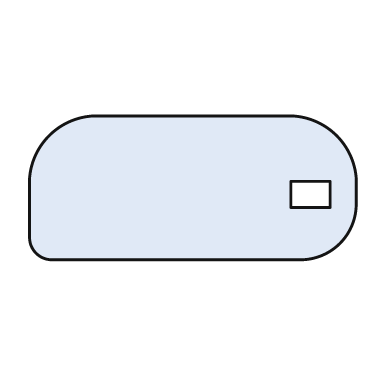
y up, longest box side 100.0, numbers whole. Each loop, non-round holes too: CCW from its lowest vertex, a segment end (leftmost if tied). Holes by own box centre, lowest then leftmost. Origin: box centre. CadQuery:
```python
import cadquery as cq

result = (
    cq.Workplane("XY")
    .moveTo(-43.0, -22.0)
    .lineTo(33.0, -22.0)
    .threePointArc((45.0, -17.0), (50.0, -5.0))
    .lineTo(50.0, 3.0)
    .threePointArc((44.0, 16.0), (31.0, 22.0))
    .lineTo(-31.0, 22.0)
    .threePointArc((-44.0, 16.0), (-50.0, 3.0))
    .lineTo(-50.0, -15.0)
    .threePointArc((-48.0, -20.0), (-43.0, -22.0))
    .close()
    .moveTo(30.0, -6.0)
    .lineTo(42.0, -6.0)
    .lineTo(42.0, 2.0)
    .lineTo(30.0, 2.0)
    .close()
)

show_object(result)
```